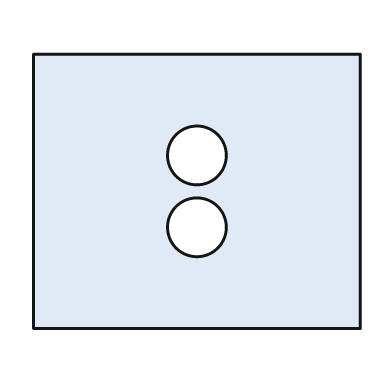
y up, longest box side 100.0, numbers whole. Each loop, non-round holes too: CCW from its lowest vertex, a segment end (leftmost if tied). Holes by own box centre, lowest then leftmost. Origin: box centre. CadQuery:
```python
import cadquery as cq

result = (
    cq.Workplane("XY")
    .moveTo(-50.0, -42.0)
    .lineTo(50.0, -42.0)
    .lineTo(50.0, 42.0)
    .lineTo(-50.0, 42.0)
    .close()
    .moveTo(0.0, -11.0)
    .circle(9.0)
    .moveTo(0.0, 11.0)
    .circle(9.0)
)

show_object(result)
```